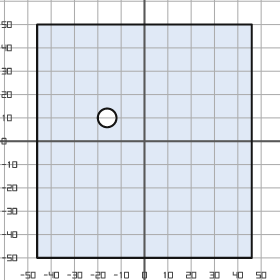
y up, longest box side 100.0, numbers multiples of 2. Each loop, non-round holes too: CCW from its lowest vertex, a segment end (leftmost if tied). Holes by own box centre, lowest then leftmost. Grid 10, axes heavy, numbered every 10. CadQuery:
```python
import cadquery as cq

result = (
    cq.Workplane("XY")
    .moveTo(-46.0, -50.0)
    .lineTo(46.0, -50.0)
    .lineTo(46.0, 50.0)
    .lineTo(-46.0, 50.0)
    .close()
    .moveTo(-16.0, 10.0)
    .circle(4.0)
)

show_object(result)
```